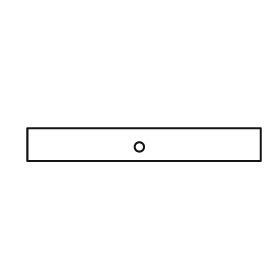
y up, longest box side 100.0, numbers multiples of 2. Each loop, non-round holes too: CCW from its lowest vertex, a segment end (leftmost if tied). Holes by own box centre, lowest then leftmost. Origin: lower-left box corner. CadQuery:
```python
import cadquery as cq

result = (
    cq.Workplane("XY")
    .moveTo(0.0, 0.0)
    .lineTo(100.0, 0.0)
    .lineTo(100.0, 14.0)
    .lineTo(0.0, 14.0)
    .close()
    .moveTo(48.0, 6.0)
    .circle(2.0)
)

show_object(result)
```